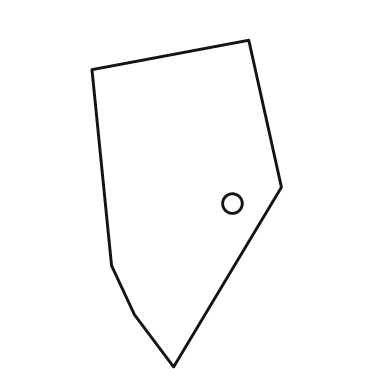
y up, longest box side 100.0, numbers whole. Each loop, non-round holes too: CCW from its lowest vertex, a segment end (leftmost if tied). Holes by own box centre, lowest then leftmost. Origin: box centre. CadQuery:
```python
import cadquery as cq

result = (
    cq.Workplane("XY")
    .moveTo(-4.0, -50.0)
    .lineTo(29.0, 5.0)
    .lineTo(19.0, 50.0)
    .lineTo(-29.0, 41.0)
    .lineTo(-23.0, -19.0)
    .lineTo(-16.0, -34.0)
    .close()
    .moveTo(14.0, 0.0)
    .circle(3.0)
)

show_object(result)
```